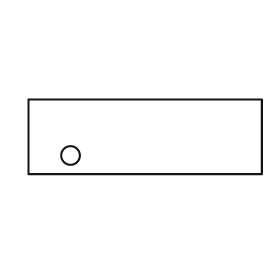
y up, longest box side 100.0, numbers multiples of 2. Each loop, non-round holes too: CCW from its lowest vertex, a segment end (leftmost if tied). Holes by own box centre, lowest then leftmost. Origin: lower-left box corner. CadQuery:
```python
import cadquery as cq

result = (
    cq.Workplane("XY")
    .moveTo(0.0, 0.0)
    .lineTo(100.0, 0.0)
    .lineTo(100.0, 32.0)
    .lineTo(0.0, 32.0)
    .close()
    .moveTo(18.0, 8.0)
    .circle(4.0)
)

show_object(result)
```